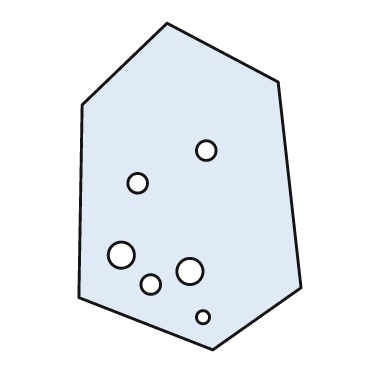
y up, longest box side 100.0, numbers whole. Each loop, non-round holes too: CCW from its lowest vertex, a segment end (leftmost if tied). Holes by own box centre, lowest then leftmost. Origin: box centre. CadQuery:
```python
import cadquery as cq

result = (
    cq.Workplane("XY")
    .moveTo(7.0, -50.0)
    .lineTo(34.0, -31.0)
    .lineTo(27.0, 32.0)
    .lineTo(-7.0, 50.0)
    .lineTo(-33.0, 25.0)
    .lineTo(-34.0, -34.0)
    .close()
    .moveTo(4.0, -40.0)
    .circle(2.0)
    .moveTo(-12.0, -30.0)
    .circle(3.0)
    .moveTo(0.0, -26.0)
    .circle(4.0)
    .moveTo(-21.0, -21.0)
    .circle(4.0)
    .moveTo(-16.0, 1.0)
    .circle(3.0)
    .moveTo(5.0, 11.0)
    .circle(3.0)
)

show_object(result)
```